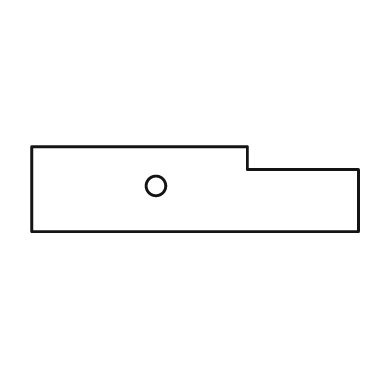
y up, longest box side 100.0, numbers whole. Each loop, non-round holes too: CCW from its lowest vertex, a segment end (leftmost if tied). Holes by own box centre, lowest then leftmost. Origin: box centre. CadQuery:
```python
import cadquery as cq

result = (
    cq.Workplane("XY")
    .moveTo(-50.0, -13.0)
    .lineTo(50.0, -13.0)
    .lineTo(50.0, 6.0)
    .lineTo(16.0, 6.0)
    .lineTo(16.0, 13.0)
    .lineTo(-50.0, 13.0)
    .close()
    .moveTo(-12.0, 1.0)
    .circle(3.0)
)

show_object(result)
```